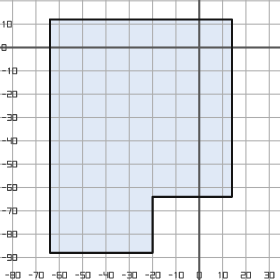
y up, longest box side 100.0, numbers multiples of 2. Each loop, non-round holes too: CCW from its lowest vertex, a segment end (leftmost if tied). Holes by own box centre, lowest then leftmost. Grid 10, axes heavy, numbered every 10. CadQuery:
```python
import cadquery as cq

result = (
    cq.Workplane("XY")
    .moveTo(-64.0, -88.0)
    .lineTo(-20.0, -88.0)
    .lineTo(-20.0, -64.0)
    .lineTo(14.0, -64.0)
    .lineTo(14.0, 12.0)
    .lineTo(-64.0, 12.0)
    .close()
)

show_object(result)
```